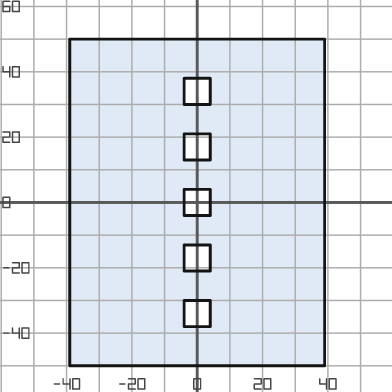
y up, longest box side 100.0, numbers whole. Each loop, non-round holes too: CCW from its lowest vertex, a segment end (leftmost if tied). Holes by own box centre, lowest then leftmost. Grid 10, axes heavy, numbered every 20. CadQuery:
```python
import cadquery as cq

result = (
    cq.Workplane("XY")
    .moveTo(-39.0, -50.0)
    .lineTo(39.0, -50.0)
    .lineTo(39.0, 50.0)
    .lineTo(-39.0, 50.0)
    .close()
    .moveTo(-4.0, -38.0)
    .lineTo(4.0, -38.0)
    .lineTo(4.0, -30.0)
    .lineTo(-4.0, -30.0)
    .close()
    .moveTo(-4.0, -21.0)
    .lineTo(4.0, -21.0)
    .lineTo(4.0, -13.0)
    .lineTo(-4.0, -13.0)
    .close()
    .moveTo(-4.0, -4.0)
    .lineTo(4.0, -4.0)
    .lineTo(4.0, 4.0)
    .lineTo(-4.0, 4.0)
    .close()
    .moveTo(-4.0, 13.0)
    .lineTo(4.0, 13.0)
    .lineTo(4.0, 21.0)
    .lineTo(-4.0, 21.0)
    .close()
    .moveTo(-4.0, 30.0)
    .lineTo(4.0, 30.0)
    .lineTo(4.0, 38.0)
    .lineTo(-4.0, 38.0)
    .close()
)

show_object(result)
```